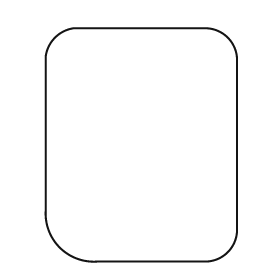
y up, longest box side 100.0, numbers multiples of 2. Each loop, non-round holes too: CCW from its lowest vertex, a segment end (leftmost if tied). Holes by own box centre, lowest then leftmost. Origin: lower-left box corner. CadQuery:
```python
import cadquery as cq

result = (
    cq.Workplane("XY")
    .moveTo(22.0, 0.0)
    .lineTo(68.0, 0.0)
    .threePointArc((78.0, 4.0), (82.0, 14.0))
    .lineTo(82.0, 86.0)
    .threePointArc((78.0, 96.0), (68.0, 100.0))
    .lineTo(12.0, 100.0)
    .threePointArc((4.0, 96.0), (0.0, 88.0))
    .lineTo(0.0, 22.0)
    .threePointArc((6.0, 6.0), (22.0, 0.0))
    .close()
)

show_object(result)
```